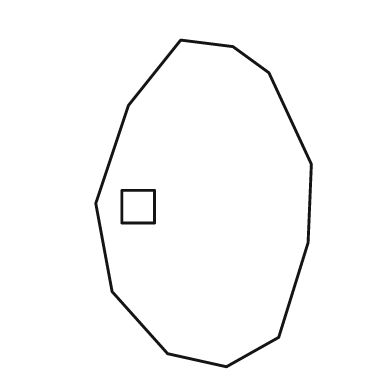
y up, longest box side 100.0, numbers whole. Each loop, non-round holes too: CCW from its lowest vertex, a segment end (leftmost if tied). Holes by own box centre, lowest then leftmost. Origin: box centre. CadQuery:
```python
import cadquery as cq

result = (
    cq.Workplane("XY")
    .moveTo(7.0, -50.0)
    .lineTo(23.0, -41.0)
    .lineTo(32.0, -12.0)
    .lineTo(33.0, 12.0)
    .lineTo(20.0, 40.0)
    .lineTo(9.0, 48.0)
    .lineTo(-7.0, 50.0)
    .lineTo(-23.0, 30.0)
    .lineTo(-33.0, 0.0)
    .lineTo(-28.0, -27.0)
    .lineTo(-11.0, -46.0)
    .close()
    .moveTo(-25.0, -6.0)
    .lineTo(-15.0, -6.0)
    .lineTo(-15.0, 4.0)
    .lineTo(-25.0, 4.0)
    .close()
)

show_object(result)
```